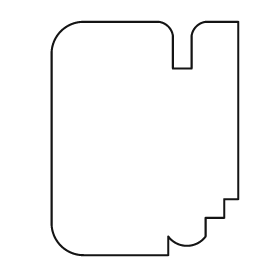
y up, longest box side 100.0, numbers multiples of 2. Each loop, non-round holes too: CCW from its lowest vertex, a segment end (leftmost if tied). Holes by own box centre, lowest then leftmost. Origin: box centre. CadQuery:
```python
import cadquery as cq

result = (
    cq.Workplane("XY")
    .moveTo(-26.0, -50.0)
    .lineTo(10.0, -50.0)
    .lineTo(10.0, -42.0)
    .threePointArc((18.0, -46.0), (26.0, -42.0))
    .lineTo(26.0, -34.0)
    .lineTo(34.0, -34.0)
    .lineTo(34.0, -26.0)
    .lineTo(40.0, -26.0)
    .lineTo(40.0, 50.0)
    .lineTo(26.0, 50.0)
    .threePointArc((22.0, 48.0), (20.0, 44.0))
    .lineTo(20.0, 30.0)
    .lineTo(12.0, 30.0)
    .lineTo(12.0, 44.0)
    .threePointArc((10.0, 48.0), (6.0, 50.0))
    .lineTo(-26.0, 50.0)
    .threePointArc((-36.0, 46.0), (-40.0, 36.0))
    .lineTo(-40.0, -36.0)
    .threePointArc((-36.0, -46.0), (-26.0, -50.0))
    .close()
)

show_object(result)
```